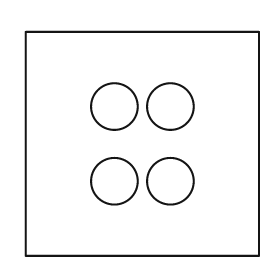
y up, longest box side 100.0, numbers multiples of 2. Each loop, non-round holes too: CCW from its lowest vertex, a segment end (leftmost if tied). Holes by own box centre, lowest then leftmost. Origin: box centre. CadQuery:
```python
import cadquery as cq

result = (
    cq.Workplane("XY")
    .moveTo(-50.0, -48.0)
    .lineTo(50.0, -48.0)
    .lineTo(50.0, 48.0)
    .lineTo(-50.0, 48.0)
    .close()
    .moveTo(-12.0, -16.0)
    .circle(10.0)
    .moveTo(12.0, -16.0)
    .circle(10.0)
    .moveTo(-12.0, 16.0)
    .circle(10.0)
    .moveTo(12.0, 16.0)
    .circle(10.0)
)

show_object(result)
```